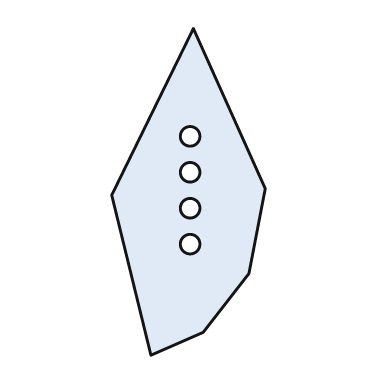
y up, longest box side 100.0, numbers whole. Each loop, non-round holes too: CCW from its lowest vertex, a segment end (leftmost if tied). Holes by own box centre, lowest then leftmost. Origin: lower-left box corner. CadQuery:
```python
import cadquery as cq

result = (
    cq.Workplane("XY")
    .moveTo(12.0, 0.0)
    .lineTo(28.0, 7.0)
    .lineTo(42.0, 25.0)
    .lineTo(47.0, 51.0)
    .lineTo(25.0, 100.0)
    .lineTo(0.0, 49.0)
    .close()
    .moveTo(24.0, 34.0)
    .circle(3.0)
    .moveTo(24.0, 45.0)
    .circle(3.0)
    .moveTo(24.0, 56.0)
    .circle(3.0)
    .moveTo(24.0, 67.0)
    .circle(3.0)
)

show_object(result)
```